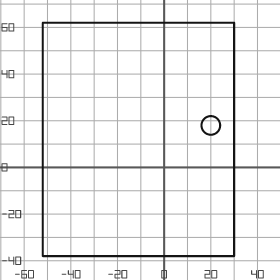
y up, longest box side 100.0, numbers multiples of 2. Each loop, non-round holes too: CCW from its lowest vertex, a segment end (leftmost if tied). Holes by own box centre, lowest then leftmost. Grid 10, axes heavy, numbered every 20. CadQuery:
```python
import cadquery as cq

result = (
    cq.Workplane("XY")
    .moveTo(-52.0, -38.0)
    .lineTo(30.0, -38.0)
    .lineTo(30.0, 62.0)
    .lineTo(-52.0, 62.0)
    .close()
    .moveTo(20.0, 18.0)
    .circle(4.0)
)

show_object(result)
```